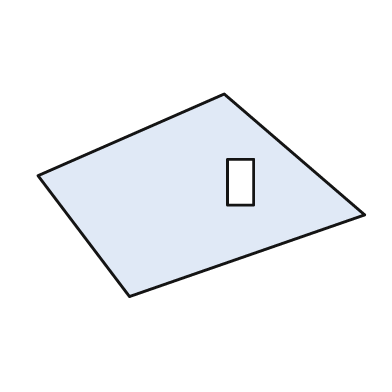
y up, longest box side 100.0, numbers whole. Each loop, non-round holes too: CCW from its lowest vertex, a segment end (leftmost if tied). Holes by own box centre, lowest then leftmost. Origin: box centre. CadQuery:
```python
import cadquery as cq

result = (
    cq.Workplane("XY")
    .moveTo(-22.0, -31.0)
    .lineTo(50.0, -6.0)
    .lineTo(7.0, 31.0)
    .lineTo(-50.0, 6.0)
    .close()
    .moveTo(8.0, -3.0)
    .lineTo(16.0, -3.0)
    .lineTo(16.0, 11.0)
    .lineTo(8.0, 11.0)
    .close()
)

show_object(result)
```